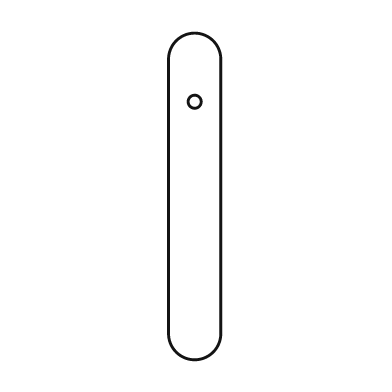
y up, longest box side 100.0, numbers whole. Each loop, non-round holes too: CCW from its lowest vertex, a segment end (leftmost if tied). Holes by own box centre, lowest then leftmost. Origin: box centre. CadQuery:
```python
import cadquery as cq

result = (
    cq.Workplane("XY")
    .moveTo(-8.0, -42.0)
    .threePointArc((0.0, -50.0), (8.0, -42.0))
    .lineTo(8.0, 42.0)
    .threePointArc((0.0, 50.0), (-8.0, 42.0))
    .close()
    .moveTo(0.0, 29.0)
    .circle(2.0)
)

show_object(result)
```